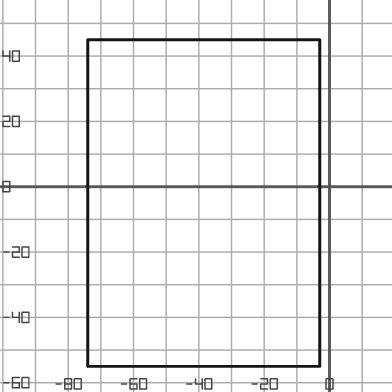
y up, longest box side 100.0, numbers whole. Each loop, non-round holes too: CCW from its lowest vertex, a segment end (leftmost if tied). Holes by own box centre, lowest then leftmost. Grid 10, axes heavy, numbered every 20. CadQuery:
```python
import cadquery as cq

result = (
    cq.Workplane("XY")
    .moveTo(-74.0, -55.0)
    .lineTo(-3.0, -55.0)
    .lineTo(-3.0, 45.0)
    .lineTo(-74.0, 45.0)
    .close()
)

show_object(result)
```